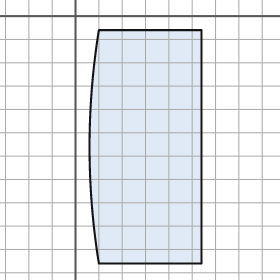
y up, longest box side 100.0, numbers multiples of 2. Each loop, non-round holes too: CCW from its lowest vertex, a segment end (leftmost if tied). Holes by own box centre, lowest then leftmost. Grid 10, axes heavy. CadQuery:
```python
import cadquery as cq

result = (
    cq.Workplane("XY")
    .moveTo(10.0, -106.0)
    .lineTo(54.0, -106.0)
    .lineTo(54.0, -6.0)
    .lineTo(10.0, -6.0)
    .threePointArc((6.0, -56.0), (10.0, -106.0))
    .close()
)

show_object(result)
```